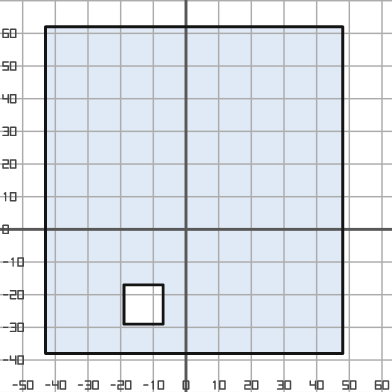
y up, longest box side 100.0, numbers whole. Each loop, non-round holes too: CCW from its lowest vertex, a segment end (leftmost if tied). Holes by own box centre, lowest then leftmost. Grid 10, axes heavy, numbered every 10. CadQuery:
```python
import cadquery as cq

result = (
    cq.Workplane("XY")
    .moveTo(-43.0, -38.0)
    .lineTo(48.0, -38.0)
    .lineTo(48.0, 62.0)
    .lineTo(-43.0, 62.0)
    .close()
    .moveTo(-19.0, -29.0)
    .lineTo(-7.0, -29.0)
    .lineTo(-7.0, -17.0)
    .lineTo(-19.0, -17.0)
    .close()
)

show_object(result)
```